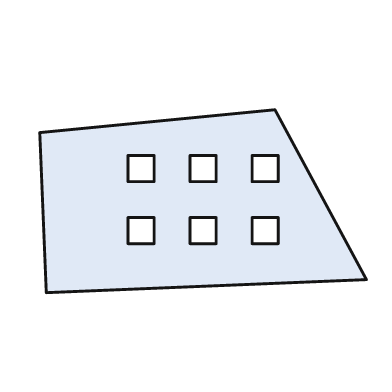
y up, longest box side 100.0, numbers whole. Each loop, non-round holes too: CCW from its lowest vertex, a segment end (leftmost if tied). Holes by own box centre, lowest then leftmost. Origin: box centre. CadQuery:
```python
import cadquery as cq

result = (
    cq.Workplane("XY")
    .moveTo(-48.0, -28.0)
    .lineTo(50.0, -24.0)
    .lineTo(22.0, 28.0)
    .lineTo(-50.0, 21.0)
    .close()
    .moveTo(-23.0, -13.0)
    .lineTo(-15.0, -13.0)
    .lineTo(-15.0, -5.0)
    .lineTo(-23.0, -5.0)
    .close()
    .moveTo(-4.0, -13.0)
    .lineTo(4.0, -13.0)
    .lineTo(4.0, -5.0)
    .lineTo(-4.0, -5.0)
    .close()
    .moveTo(15.0, -13.0)
    .lineTo(23.0, -13.0)
    .lineTo(23.0, -5.0)
    .lineTo(15.0, -5.0)
    .close()
    .moveTo(-23.0, 6.0)
    .lineTo(-15.0, 6.0)
    .lineTo(-15.0, 14.0)
    .lineTo(-23.0, 14.0)
    .close()
    .moveTo(-4.0, 6.0)
    .lineTo(4.0, 6.0)
    .lineTo(4.0, 14.0)
    .lineTo(-4.0, 14.0)
    .close()
    .moveTo(15.0, 6.0)
    .lineTo(23.0, 6.0)
    .lineTo(23.0, 14.0)
    .lineTo(15.0, 14.0)
    .close()
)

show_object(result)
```